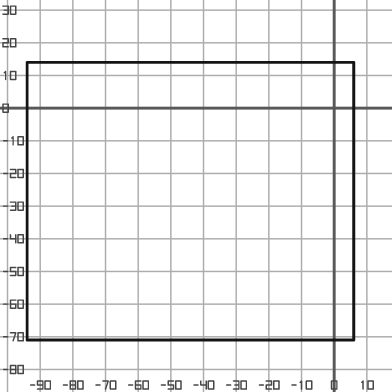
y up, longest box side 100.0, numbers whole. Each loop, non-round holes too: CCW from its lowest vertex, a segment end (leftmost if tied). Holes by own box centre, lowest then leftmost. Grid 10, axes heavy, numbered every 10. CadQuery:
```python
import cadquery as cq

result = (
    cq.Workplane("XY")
    .moveTo(-94.0, -71.0)
    .lineTo(6.0, -71.0)
    .lineTo(6.0, 14.0)
    .lineTo(-94.0, 14.0)
    .close()
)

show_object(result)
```